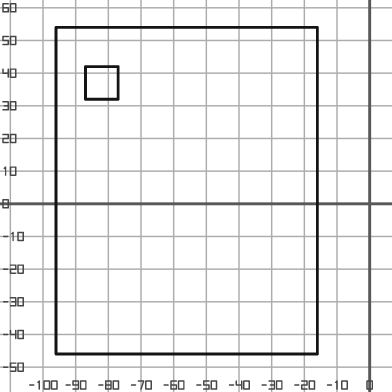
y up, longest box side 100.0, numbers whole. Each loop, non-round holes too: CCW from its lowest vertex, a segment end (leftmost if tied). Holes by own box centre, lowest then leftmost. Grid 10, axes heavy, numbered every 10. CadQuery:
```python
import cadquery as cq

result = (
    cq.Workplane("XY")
    .moveTo(-96.0, -46.0)
    .lineTo(-16.0, -46.0)
    .lineTo(-16.0, 54.0)
    .lineTo(-96.0, 54.0)
    .close()
    .moveTo(-87.0, 32.0)
    .lineTo(-77.0, 32.0)
    .lineTo(-77.0, 42.0)
    .lineTo(-87.0, 42.0)
    .close()
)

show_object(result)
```